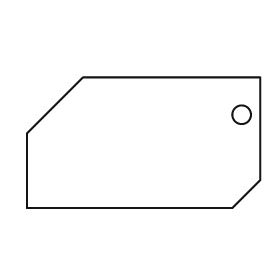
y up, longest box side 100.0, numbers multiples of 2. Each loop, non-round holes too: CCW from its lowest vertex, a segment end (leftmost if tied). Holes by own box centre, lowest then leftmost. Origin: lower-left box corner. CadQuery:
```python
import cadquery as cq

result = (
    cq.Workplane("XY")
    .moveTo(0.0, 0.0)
    .lineTo(88.0, 0.0)
    .lineTo(100.0, 12.0)
    .lineTo(100.0, 56.0)
    .lineTo(24.0, 56.0)
    .lineTo(0.0, 32.0)
    .close()
    .moveTo(92.0, 40.0)
    .circle(4.0)
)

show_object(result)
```